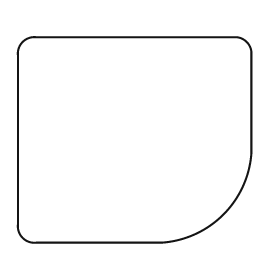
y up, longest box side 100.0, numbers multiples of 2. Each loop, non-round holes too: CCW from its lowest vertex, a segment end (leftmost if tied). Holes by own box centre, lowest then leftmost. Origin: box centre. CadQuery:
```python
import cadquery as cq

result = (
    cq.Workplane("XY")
    .moveTo(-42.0, -44.0)
    .lineTo(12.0, -44.0)
    .threePointArc((38.0, -32.0), (50.0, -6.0))
    .lineTo(50.0, 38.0)
    .threePointArc((48.0, 42.0), (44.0, 44.0))
    .lineTo(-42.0, 44.0)
    .threePointArc((-48.0, 42.0), (-50.0, 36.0))
    .lineTo(-50.0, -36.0)
    .threePointArc((-48.0, -42.0), (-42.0, -44.0))
    .close()
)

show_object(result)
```